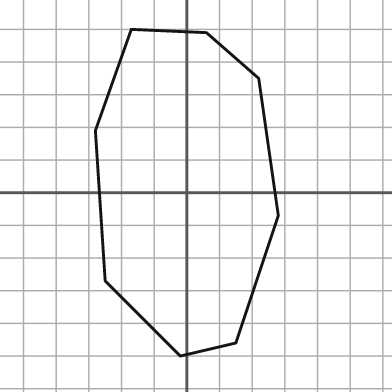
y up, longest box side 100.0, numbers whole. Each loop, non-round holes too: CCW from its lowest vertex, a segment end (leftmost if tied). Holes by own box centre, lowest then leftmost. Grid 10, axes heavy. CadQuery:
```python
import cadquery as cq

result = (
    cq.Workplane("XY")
    .moveTo(-2.0, -50.0)
    .lineTo(15.0, -46.0)
    .lineTo(28.0, -7.0)
    .lineTo(22.0, 35.0)
    .lineTo(6.0, 49.0)
    .lineTo(-17.0, 50.0)
    .lineTo(-28.0, 19.0)
    .lineTo(-25.0, -27.0)
    .close()
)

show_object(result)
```